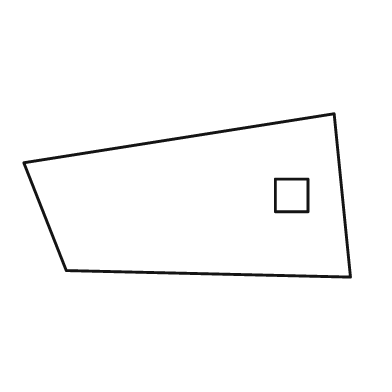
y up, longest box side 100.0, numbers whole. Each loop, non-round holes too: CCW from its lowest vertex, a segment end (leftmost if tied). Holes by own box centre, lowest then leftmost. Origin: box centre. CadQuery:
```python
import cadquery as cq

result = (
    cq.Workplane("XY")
    .moveTo(50.0, -25.0)
    .lineTo(45.0, 25.0)
    .lineTo(-50.0, 10.0)
    .lineTo(-37.0, -23.0)
    .close()
    .moveTo(27.0, -5.0)
    .lineTo(37.0, -5.0)
    .lineTo(37.0, 5.0)
    .lineTo(27.0, 5.0)
    .close()
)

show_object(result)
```